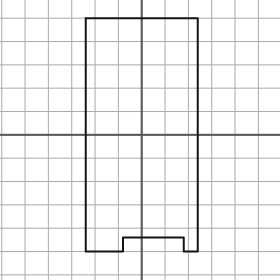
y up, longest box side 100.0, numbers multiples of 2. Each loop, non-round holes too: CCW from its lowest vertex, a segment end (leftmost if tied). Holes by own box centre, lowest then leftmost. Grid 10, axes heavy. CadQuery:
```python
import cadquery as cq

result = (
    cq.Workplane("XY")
    .moveTo(-24.0, -50.0)
    .lineTo(-8.0, -50.0)
    .lineTo(-8.0, -44.0)
    .lineTo(18.0, -44.0)
    .lineTo(18.0, -50.0)
    .lineTo(24.0, -50.0)
    .lineTo(24.0, 50.0)
    .lineTo(-24.0, 50.0)
    .close()
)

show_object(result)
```